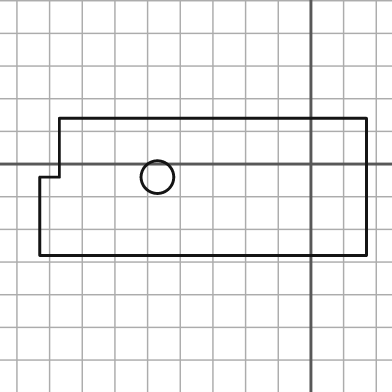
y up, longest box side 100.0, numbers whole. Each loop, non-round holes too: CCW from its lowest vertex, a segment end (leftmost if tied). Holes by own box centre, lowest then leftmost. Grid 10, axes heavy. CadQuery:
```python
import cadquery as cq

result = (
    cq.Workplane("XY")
    .moveTo(-83.0, -28.0)
    .lineTo(17.0, -28.0)
    .lineTo(17.0, 14.0)
    .lineTo(-77.0, 14.0)
    .lineTo(-77.0, -4.0)
    .lineTo(-83.0, -4.0)
    .close()
    .moveTo(-47.0, -4.0)
    .circle(5.0)
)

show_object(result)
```